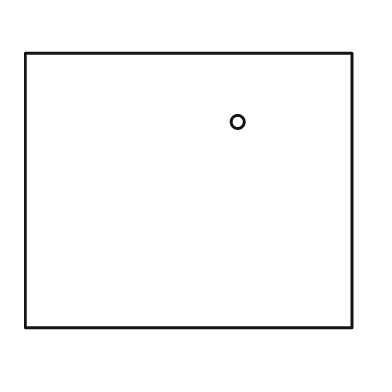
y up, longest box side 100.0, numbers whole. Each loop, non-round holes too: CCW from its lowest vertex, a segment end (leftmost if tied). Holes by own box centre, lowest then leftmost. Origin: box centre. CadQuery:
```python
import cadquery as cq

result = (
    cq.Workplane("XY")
    .moveTo(-50.0, -42.0)
    .lineTo(50.0, -42.0)
    .lineTo(50.0, 42.0)
    .lineTo(-50.0, 42.0)
    .close()
    .moveTo(15.0, 21.0)
    .circle(2.0)
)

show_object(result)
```